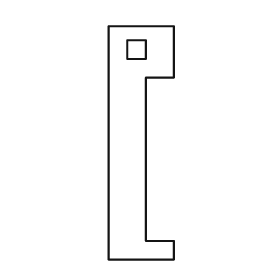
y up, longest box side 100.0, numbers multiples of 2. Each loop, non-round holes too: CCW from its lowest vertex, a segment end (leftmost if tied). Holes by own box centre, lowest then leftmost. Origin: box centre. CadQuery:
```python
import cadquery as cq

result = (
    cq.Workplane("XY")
    .moveTo(-14.0, -50.0)
    .lineTo(14.0, -50.0)
    .lineTo(14.0, -42.0)
    .lineTo(2.0, -42.0)
    .lineTo(2.0, 28.0)
    .lineTo(14.0, 28.0)
    .lineTo(14.0, 50.0)
    .lineTo(-14.0, 50.0)
    .close()
    .moveTo(-6.0, 36.0)
    .lineTo(2.0, 36.0)
    .lineTo(2.0, 44.0)
    .lineTo(-6.0, 44.0)
    .close()
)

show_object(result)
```